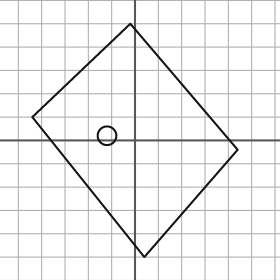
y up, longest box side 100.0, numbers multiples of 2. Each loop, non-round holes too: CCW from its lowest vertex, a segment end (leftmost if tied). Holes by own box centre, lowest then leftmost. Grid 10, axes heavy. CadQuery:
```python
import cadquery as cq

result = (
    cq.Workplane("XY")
    .moveTo(4.0, -50.0)
    .lineTo(44.0, -4.0)
    .lineTo(-2.0, 50.0)
    .lineTo(-44.0, 10.0)
    .close()
    .moveTo(-12.0, 2.0)
    .circle(4.0)
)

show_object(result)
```